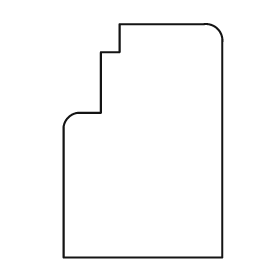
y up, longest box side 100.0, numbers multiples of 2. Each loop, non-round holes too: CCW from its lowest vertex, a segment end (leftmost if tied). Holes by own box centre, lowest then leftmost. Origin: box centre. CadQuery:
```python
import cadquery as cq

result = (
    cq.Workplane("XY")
    .moveTo(-34.0, -50.0)
    .lineTo(34.0, -50.0)
    .lineTo(34.0, 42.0)
    .threePointArc((32.0, 48.0), (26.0, 50.0))
    .lineTo(-10.0, 50.0)
    .lineTo(-10.0, 38.0)
    .lineTo(-18.0, 38.0)
    .lineTo(-18.0, 12.0)
    .lineTo(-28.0, 12.0)
    .threePointArc((-32.0, 10.0), (-34.0, 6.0))
    .close()
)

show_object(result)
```